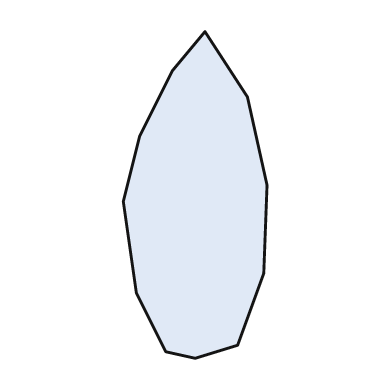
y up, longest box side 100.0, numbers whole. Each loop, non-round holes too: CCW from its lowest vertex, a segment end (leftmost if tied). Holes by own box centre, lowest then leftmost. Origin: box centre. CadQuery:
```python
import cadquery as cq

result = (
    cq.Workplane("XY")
    .moveTo(0.0, -50.0)
    .lineTo(13.0, -46.0)
    .lineTo(21.0, -24.0)
    .lineTo(22.0, 3.0)
    .lineTo(16.0, 30.0)
    .lineTo(3.0, 50.0)
    .lineTo(-7.0, 38.0)
    .lineTo(-17.0, 18.0)
    .lineTo(-22.0, -2.0)
    .lineTo(-18.0, -30.0)
    .lineTo(-9.0, -48.0)
    .close()
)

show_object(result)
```